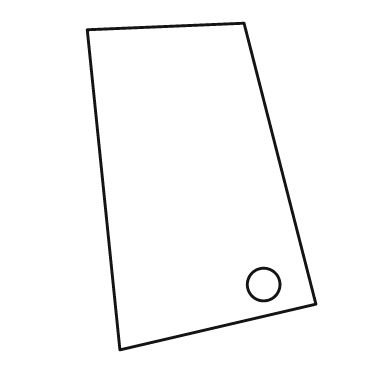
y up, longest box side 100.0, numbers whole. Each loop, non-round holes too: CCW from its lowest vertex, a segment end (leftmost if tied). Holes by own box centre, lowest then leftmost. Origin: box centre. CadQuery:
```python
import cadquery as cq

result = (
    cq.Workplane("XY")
    .moveTo(-25.0, -50.0)
    .lineTo(35.0, -36.0)
    .lineTo(13.0, 50.0)
    .lineTo(-35.0, 48.0)
    .close()
    .moveTo(19.0, -30.0)
    .circle(5.0)
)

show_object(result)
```